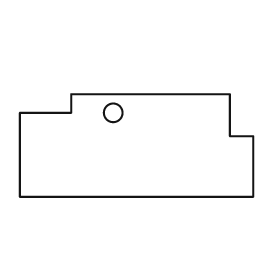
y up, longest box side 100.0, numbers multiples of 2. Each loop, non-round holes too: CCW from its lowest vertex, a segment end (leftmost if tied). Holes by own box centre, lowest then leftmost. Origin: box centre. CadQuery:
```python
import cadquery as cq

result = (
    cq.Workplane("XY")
    .moveTo(-50.0, -22.0)
    .lineTo(50.0, -22.0)
    .lineTo(50.0, 4.0)
    .lineTo(40.0, 4.0)
    .lineTo(40.0, 22.0)
    .lineTo(-28.0, 22.0)
    .lineTo(-28.0, 14.0)
    .lineTo(-50.0, 14.0)
    .close()
    .moveTo(-10.0, 14.0)
    .circle(4.0)
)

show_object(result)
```